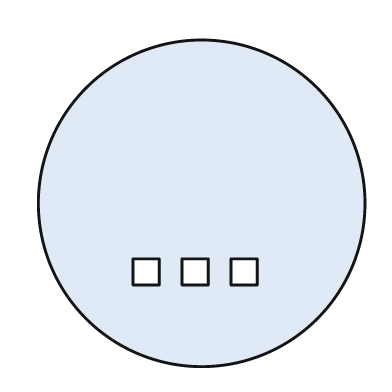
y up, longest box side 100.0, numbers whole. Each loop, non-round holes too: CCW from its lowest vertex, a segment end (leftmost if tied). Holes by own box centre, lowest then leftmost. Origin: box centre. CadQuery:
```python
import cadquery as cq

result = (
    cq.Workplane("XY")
    .moveTo(0.0, 0.0)
    .circle(50.0)
    .moveTo(-21.0, -25.0)
    .lineTo(-13.0, -25.0)
    .lineTo(-13.0, -17.0)
    .lineTo(-21.0, -17.0)
    .close()
    .moveTo(-6.0, -25.0)
    .lineTo(2.0, -25.0)
    .lineTo(2.0, -17.0)
    .lineTo(-6.0, -17.0)
    .close()
    .moveTo(9.0, -25.0)
    .lineTo(17.0, -25.0)
    .lineTo(17.0, -17.0)
    .lineTo(9.0, -17.0)
    .close()
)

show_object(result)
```